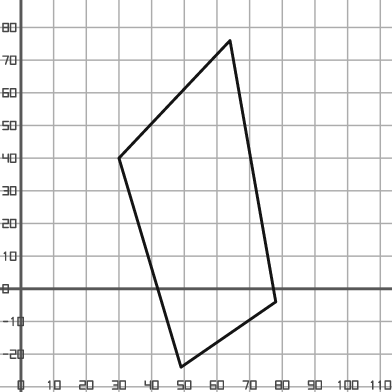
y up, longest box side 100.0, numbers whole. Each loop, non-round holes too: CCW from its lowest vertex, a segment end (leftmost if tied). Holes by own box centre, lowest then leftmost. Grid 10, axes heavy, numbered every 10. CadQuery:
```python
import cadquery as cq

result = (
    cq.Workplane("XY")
    .moveTo(49.0, -24.0)
    .lineTo(78.0, -4.0)
    .lineTo(64.0, 76.0)
    .lineTo(30.0, 40.0)
    .close()
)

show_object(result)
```